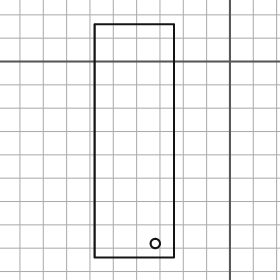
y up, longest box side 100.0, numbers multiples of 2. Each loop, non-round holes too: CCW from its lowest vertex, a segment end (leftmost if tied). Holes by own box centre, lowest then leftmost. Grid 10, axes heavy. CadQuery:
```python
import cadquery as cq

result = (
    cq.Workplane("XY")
    .moveTo(-58.0, -84.0)
    .lineTo(-24.0, -84.0)
    .lineTo(-24.0, 16.0)
    .lineTo(-58.0, 16.0)
    .close()
    .moveTo(-32.0, -78.0)
    .circle(2.0)
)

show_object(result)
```